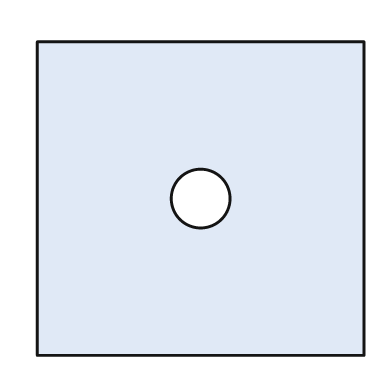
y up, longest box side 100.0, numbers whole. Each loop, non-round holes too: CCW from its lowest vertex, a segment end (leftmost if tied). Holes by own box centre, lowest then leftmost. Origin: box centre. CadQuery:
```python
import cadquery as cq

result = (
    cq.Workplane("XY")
    .moveTo(-50.0, -48.0)
    .lineTo(50.0, -48.0)
    .lineTo(50.0, 48.0)
    .lineTo(-50.0, 48.0)
    .close()
    .moveTo(0.0, 0.0)
    .circle(9.0)
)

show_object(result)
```